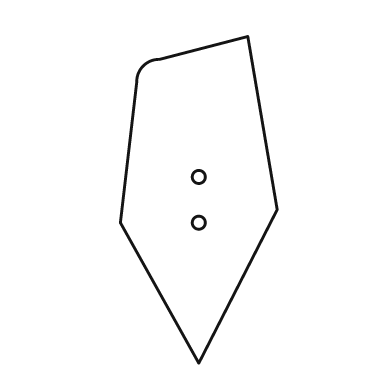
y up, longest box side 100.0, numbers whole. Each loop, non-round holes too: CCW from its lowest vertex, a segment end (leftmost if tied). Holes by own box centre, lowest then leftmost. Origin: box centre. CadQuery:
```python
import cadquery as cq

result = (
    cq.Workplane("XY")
    .moveTo(0.0, -50.0)
    .lineTo(24.0, -3.0)
    .lineTo(15.0, 50.0)
    .lineTo(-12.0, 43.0)
    .threePointArc((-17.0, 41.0), (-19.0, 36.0))
    .lineTo(-24.0, -7.0)
    .close()
    .moveTo(0.0, -7.0)
    .circle(2.0)
    .moveTo(0.0, 7.0)
    .circle(2.0)
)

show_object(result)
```